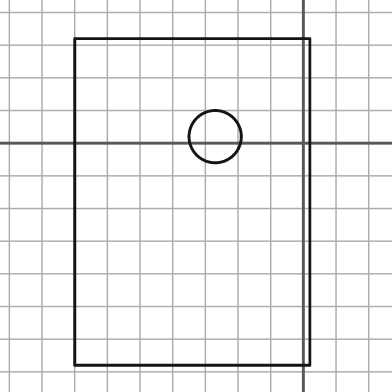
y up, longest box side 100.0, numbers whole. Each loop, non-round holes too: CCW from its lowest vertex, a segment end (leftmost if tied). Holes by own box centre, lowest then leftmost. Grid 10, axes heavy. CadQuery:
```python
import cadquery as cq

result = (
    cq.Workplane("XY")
    .moveTo(-70.0, -68.0)
    .lineTo(2.0, -68.0)
    .lineTo(2.0, 32.0)
    .lineTo(-70.0, 32.0)
    .close()
    .moveTo(-27.0, 2.0)
    .circle(8.0)
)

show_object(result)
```